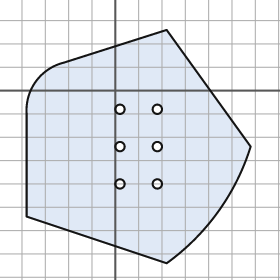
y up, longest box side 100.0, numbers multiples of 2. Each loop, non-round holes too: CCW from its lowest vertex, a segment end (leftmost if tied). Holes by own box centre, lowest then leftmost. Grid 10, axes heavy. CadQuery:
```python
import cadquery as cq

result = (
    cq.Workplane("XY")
    .moveTo(22.0, -74.0)
    .threePointArc((44.0, -52.0), (58.0, -24.0))
    .lineTo(22.0, 26.0)
    .lineTo(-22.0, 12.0)
    .threePointArc((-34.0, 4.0), (-38.0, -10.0))
    .lineTo(-38.0, -54.0)
    .close()
    .moveTo(2.0, -40.0)
    .circle(2.0)
    .moveTo(18.0, -40.0)
    .circle(2.0)
    .moveTo(2.0, -24.0)
    .circle(2.0)
    .moveTo(18.0, -24.0)
    .circle(2.0)
    .moveTo(2.0, -8.0)
    .circle(2.0)
    .moveTo(18.0, -8.0)
    .circle(2.0)
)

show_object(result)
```